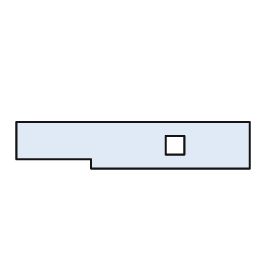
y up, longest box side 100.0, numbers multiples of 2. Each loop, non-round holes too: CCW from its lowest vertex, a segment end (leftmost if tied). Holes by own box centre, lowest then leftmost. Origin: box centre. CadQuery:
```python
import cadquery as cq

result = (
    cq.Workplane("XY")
    .moveTo(-18.0, -10.0)
    .lineTo(50.0, -10.0)
    .lineTo(50.0, 10.0)
    .lineTo(-50.0, 10.0)
    .lineTo(-50.0, -6.0)
    .lineTo(-18.0, -6.0)
    .close()
    .moveTo(14.0, -4.0)
    .lineTo(22.0, -4.0)
    .lineTo(22.0, 4.0)
    .lineTo(14.0, 4.0)
    .close()
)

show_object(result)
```